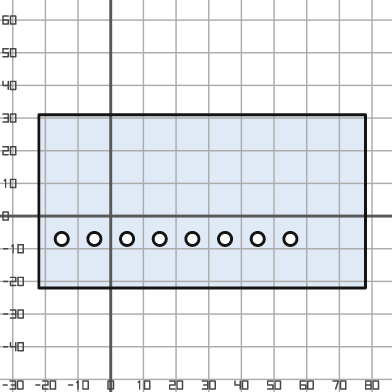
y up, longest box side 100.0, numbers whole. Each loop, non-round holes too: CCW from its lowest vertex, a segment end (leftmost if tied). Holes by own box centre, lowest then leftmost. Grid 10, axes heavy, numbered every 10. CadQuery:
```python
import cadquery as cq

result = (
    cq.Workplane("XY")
    .moveTo(-22.0, -22.0)
    .lineTo(78.0, -22.0)
    .lineTo(78.0, 31.0)
    .lineTo(-22.0, 31.0)
    .close()
    .moveTo(-15.0, -7.0)
    .circle(2.0)
    .moveTo(-5.0, -7.0)
    .circle(2.0)
    .moveTo(5.0, -7.0)
    .circle(2.0)
    .moveTo(15.0, -7.0)
    .circle(2.0)
    .moveTo(25.0, -7.0)
    .circle(2.0)
    .moveTo(35.0, -7.0)
    .circle(2.0)
    .moveTo(45.0, -7.0)
    .circle(2.0)
    .moveTo(55.0, -7.0)
    .circle(2.0)
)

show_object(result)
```